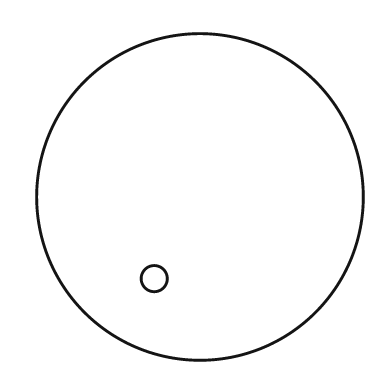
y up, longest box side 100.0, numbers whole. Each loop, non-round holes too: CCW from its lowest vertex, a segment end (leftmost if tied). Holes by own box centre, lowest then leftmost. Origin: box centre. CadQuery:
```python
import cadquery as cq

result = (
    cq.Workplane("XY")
    .moveTo(0.0, 0.0)
    .circle(50.0)
    .moveTo(-14.0, -25.0)
    .circle(4.0)
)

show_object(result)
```